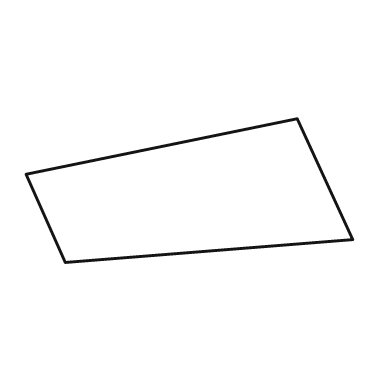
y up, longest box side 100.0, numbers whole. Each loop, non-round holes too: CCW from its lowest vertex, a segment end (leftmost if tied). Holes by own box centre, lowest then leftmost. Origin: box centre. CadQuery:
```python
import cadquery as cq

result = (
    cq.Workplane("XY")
    .moveTo(-38.0, -22.0)
    .lineTo(50.0, -15.0)
    .lineTo(33.0, 22.0)
    .lineTo(-50.0, 5.0)
    .close()
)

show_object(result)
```